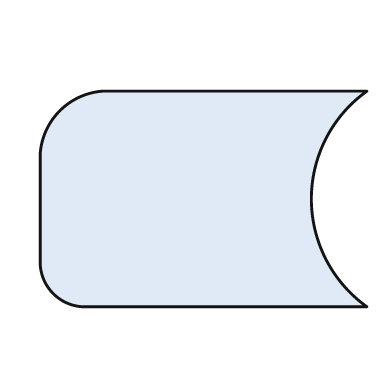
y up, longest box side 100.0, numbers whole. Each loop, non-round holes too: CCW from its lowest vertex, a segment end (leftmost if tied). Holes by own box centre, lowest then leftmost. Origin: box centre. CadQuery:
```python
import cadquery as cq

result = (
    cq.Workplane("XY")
    .moveTo(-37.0, -33.0)
    .lineTo(50.0, -33.0)
    .threePointArc((33.0, 0.0), (50.0, 33.0))
    .lineTo(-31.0, 33.0)
    .threePointArc((-44.0, 27.0), (-50.0, 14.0))
    .lineTo(-50.0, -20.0)
    .threePointArc((-46.0, -29.0), (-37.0, -33.0))
    .close()
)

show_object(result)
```